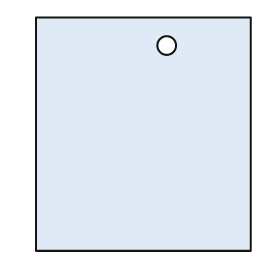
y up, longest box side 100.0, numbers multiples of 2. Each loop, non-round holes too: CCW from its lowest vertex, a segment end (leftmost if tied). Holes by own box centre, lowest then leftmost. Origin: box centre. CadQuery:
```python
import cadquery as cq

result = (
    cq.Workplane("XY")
    .moveTo(-46.0, -50.0)
    .lineTo(46.0, -50.0)
    .lineTo(46.0, 50.0)
    .lineTo(-46.0, 50.0)
    .close()
    .moveTo(10.0, 38.0)
    .circle(4.0)
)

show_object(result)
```